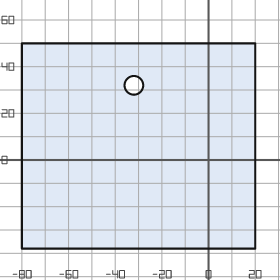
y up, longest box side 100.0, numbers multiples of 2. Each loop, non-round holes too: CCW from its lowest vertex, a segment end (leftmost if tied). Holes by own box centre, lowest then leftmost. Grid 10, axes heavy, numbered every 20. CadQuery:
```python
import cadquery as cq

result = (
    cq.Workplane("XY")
    .moveTo(-80.0, -38.0)
    .lineTo(20.0, -38.0)
    .lineTo(20.0, 50.0)
    .lineTo(-80.0, 50.0)
    .close()
    .moveTo(-32.0, 32.0)
    .circle(4.0)
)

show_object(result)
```